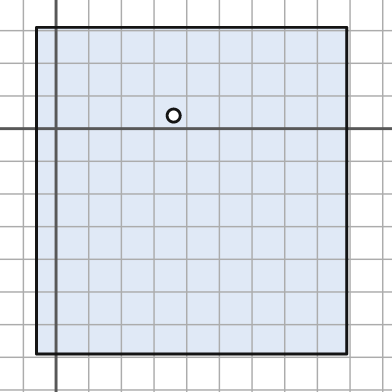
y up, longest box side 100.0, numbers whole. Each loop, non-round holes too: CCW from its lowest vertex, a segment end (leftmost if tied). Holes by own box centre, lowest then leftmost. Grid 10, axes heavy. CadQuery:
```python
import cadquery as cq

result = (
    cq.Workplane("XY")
    .moveTo(-6.0, -69.0)
    .lineTo(89.0, -69.0)
    .lineTo(89.0, 31.0)
    .lineTo(-6.0, 31.0)
    .close()
    .moveTo(36.0, 4.0)
    .circle(2.0)
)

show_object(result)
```